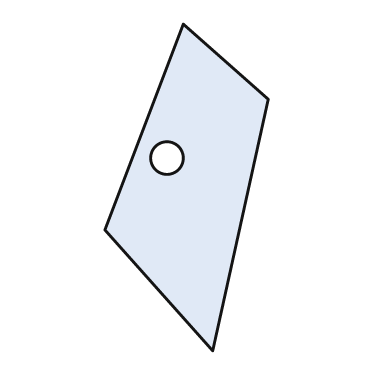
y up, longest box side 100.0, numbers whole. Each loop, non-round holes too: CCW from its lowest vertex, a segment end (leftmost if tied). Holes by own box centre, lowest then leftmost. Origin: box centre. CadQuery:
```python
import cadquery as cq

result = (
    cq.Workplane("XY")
    .moveTo(8.0, -50.0)
    .lineTo(25.0, 27.0)
    .lineTo(-1.0, 50.0)
    .lineTo(-25.0, -13.0)
    .close()
    .moveTo(-6.0, 9.0)
    .circle(5.0)
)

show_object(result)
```